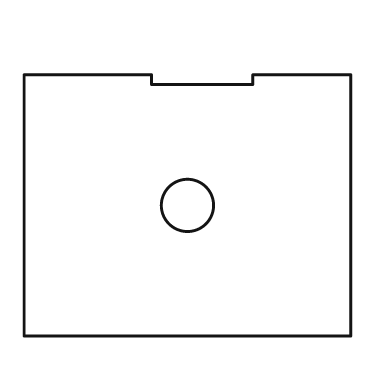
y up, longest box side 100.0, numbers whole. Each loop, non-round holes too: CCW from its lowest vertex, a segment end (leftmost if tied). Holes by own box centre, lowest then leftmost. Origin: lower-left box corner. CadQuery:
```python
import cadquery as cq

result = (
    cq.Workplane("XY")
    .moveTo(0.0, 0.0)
    .lineTo(100.0, 0.0)
    .lineTo(100.0, 80.0)
    .lineTo(70.0, 80.0)
    .lineTo(70.0, 77.0)
    .lineTo(39.0, 77.0)
    .lineTo(39.0, 80.0)
    .lineTo(0.0, 80.0)
    .close()
    .moveTo(50.0, 40.0)
    .circle(8.0)
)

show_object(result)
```